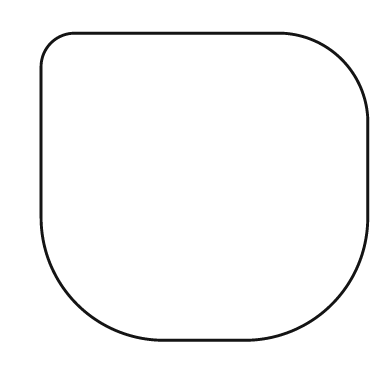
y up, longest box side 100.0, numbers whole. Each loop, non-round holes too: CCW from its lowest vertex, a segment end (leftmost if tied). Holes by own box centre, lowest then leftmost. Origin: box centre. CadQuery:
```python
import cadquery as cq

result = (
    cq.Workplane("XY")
    .moveTo(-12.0, -47.0)
    .lineTo(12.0, -47.0)
    .threePointArc((39.0, -36.0), (50.0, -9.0))
    .lineTo(50.0, 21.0)
    .threePointArc((42.0, 39.0), (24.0, 47.0))
    .lineTo(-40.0, 47.0)
    .threePointArc((-47.0, 44.0), (-50.0, 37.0))
    .lineTo(-50.0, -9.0)
    .threePointArc((-39.0, -36.0), (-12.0, -47.0))
    .close()
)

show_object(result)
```